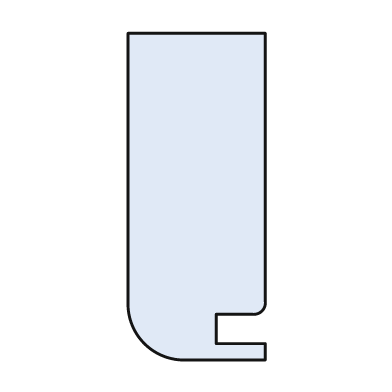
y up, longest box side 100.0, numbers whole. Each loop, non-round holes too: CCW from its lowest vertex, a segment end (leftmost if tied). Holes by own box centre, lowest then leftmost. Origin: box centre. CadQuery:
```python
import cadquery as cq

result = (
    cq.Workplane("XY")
    .moveTo(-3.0, -50.0)
    .lineTo(21.0, -50.0)
    .lineTo(21.0, -45.0)
    .lineTo(6.0, -45.0)
    .lineTo(6.0, -36.0)
    .lineTo(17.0, -36.0)
    .threePointArc((20.0, -35.0), (21.0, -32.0))
    .lineTo(21.0, 50.0)
    .lineTo(-21.0, 50.0)
    .lineTo(-21.0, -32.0)
    .threePointArc((-16.0, -45.0), (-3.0, -50.0))
    .close()
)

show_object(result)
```